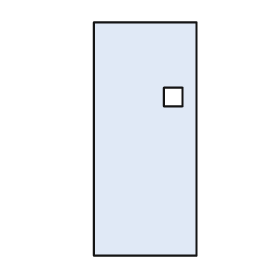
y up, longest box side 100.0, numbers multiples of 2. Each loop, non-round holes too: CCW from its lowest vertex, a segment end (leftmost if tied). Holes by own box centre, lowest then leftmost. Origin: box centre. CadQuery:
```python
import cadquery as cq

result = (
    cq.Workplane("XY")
    .moveTo(-22.0, -50.0)
    .lineTo(22.0, -50.0)
    .lineTo(22.0, 50.0)
    .lineTo(-22.0, 50.0)
    .close()
    .moveTo(8.0, 14.0)
    .lineTo(16.0, 14.0)
    .lineTo(16.0, 22.0)
    .lineTo(8.0, 22.0)
    .close()
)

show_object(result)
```